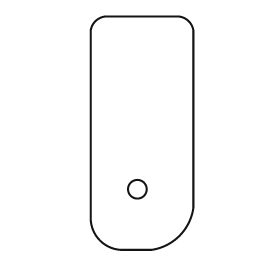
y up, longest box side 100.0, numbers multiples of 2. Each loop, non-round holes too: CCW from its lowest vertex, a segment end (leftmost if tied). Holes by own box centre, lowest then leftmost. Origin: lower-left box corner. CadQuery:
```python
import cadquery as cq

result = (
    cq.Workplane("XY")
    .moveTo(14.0, 0.0)
    .lineTo(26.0, 0.0)
    .threePointArc((38.0, 6.0), (44.0, 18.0))
    .lineTo(44.0, 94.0)
    .threePointArc((42.0, 98.0), (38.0, 100.0))
    .lineTo(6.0, 100.0)
    .threePointArc((2.0, 98.0), (0.0, 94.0))
    .lineTo(0.0, 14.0)
    .threePointArc((4.0, 4.0), (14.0, 0.0))
    .close()
    .moveTo(20.0, 26.0)
    .circle(4.0)
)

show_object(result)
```